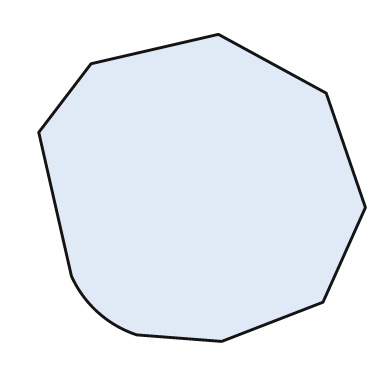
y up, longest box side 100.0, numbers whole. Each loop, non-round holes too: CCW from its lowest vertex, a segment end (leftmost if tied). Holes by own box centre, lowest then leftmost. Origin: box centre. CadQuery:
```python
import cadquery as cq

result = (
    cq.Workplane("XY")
    .moveTo(6.0, -47.0)
    .lineTo(37.0, -35.0)
    .lineTo(50.0, -6.0)
    .lineTo(38.0, 29.0)
    .lineTo(5.0, 47.0)
    .lineTo(-34.0, 38.0)
    .lineTo(-50.0, 17.0)
    .lineTo(-40.0, -27.0)
    .threePointArc((-32.0, -38.0), (-20.0, -45.0))
    .close()
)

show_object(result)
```